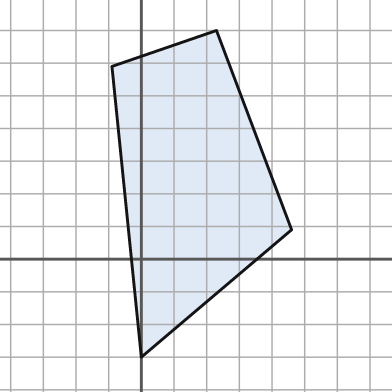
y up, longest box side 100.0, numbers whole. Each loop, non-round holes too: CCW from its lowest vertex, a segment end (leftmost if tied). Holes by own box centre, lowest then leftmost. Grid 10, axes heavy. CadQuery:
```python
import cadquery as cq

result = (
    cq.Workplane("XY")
    .moveTo(0.0, -30.0)
    .lineTo(46.0, 9.0)
    .lineTo(23.0, 70.0)
    .lineTo(-9.0, 59.0)
    .close()
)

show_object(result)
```